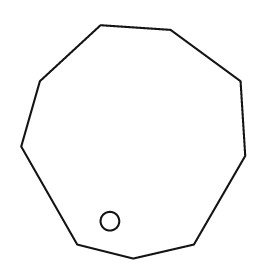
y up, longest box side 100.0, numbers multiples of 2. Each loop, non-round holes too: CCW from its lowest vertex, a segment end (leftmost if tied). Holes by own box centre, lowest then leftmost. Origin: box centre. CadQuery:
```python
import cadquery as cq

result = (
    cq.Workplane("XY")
    .moveTo(0.0, -50.0)
    .lineTo(26.0, -44.0)
    .lineTo(48.0, -6.0)
    .lineTo(46.0, 26.0)
    .lineTo(16.0, 48.0)
    .lineTo(-14.0, 50.0)
    .lineTo(-40.0, 26.0)
    .lineTo(-48.0, -2.0)
    .lineTo(-24.0, -44.0)
    .close()
    .moveTo(-10.0, -34.0)
    .circle(4.0)
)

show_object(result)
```